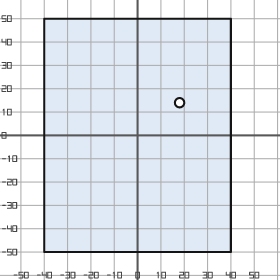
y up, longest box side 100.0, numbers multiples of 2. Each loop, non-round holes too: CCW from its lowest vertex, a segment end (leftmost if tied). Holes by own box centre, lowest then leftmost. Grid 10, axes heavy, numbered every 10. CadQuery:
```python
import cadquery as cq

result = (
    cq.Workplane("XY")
    .moveTo(-40.0, -50.0)
    .lineTo(40.0, -50.0)
    .lineTo(40.0, 50.0)
    .lineTo(-40.0, 50.0)
    .close()
    .moveTo(18.0, 14.0)
    .circle(2.0)
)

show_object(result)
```